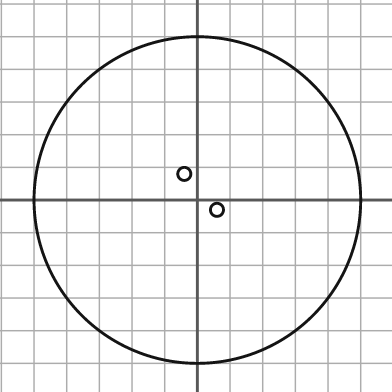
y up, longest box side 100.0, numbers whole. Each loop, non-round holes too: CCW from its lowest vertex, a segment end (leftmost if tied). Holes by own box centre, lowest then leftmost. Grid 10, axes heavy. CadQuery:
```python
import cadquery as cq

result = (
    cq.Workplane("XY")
    .moveTo(0.0, 0.0)
    .circle(50.0)
    .moveTo(6.0, -3.0)
    .circle(2.0)
    .moveTo(-4.0, 8.0)
    .circle(2.0)
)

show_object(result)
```